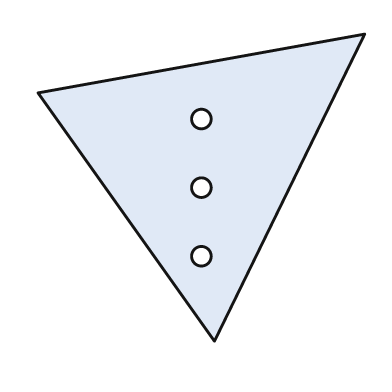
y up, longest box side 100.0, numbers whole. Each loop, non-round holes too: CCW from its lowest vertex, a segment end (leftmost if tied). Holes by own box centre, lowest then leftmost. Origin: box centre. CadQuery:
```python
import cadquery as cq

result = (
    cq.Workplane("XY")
    .moveTo(4.0, -47.0)
    .lineTo(50.0, 47.0)
    .lineTo(-50.0, 29.0)
    .close()
    .moveTo(0.0, -21.0)
    .circle(3.0)
    .moveTo(0.0, 0.0)
    .circle(3.0)
    .moveTo(0.0, 21.0)
    .circle(3.0)
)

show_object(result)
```